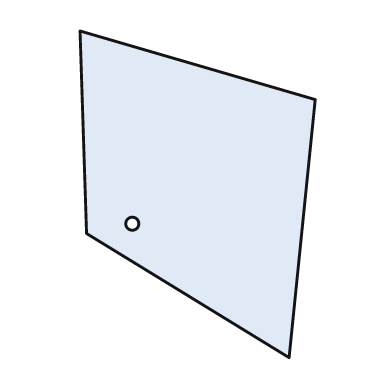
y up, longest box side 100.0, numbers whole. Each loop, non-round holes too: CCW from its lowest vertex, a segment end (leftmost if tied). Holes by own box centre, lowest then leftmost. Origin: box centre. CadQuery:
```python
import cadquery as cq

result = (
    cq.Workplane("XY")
    .moveTo(28.0, -50.0)
    .lineTo(36.0, 29.0)
    .lineTo(-36.0, 50.0)
    .lineTo(-34.0, -12.0)
    .close()
    .moveTo(-20.0, -9.0)
    .circle(2.0)
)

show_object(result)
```